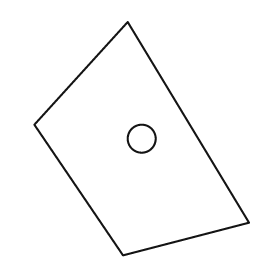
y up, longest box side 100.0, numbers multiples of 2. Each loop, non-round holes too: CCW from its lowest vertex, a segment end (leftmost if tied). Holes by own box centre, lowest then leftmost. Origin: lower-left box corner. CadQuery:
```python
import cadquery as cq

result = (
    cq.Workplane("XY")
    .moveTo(38.0, 0.0)
    .lineTo(92.0, 14.0)
    .lineTo(40.0, 100.0)
    .lineTo(0.0, 56.0)
    .close()
    .moveTo(46.0, 50.0)
    .circle(6.0)
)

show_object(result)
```